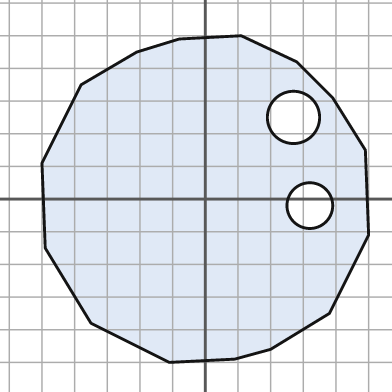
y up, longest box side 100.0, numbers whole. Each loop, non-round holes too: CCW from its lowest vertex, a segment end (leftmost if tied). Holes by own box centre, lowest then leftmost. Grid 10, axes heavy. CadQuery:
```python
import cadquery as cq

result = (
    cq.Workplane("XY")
    .moveTo(-11.0, -50.0)
    .lineTo(9.0, -49.0)
    .lineTo(20.0, -46.0)
    .lineTo(38.0, -35.0)
    .lineTo(50.0, -11.0)
    .lineTo(49.0, 15.0)
    .lineTo(39.0, 31.0)
    .lineTo(28.0, 42.0)
    .lineTo(11.0, 50.0)
    .lineTo(-8.0, 49.0)
    .lineTo(-21.0, 45.0)
    .lineTo(-38.0, 35.0)
    .lineTo(-50.0, 11.0)
    .lineTo(-49.0, -15.0)
    .lineTo(-35.0, -38.0)
    .close()
    .moveTo(32.0, -2.0)
    .circle(7.0)
    .moveTo(27.0, 25.0)
    .circle(8.0)
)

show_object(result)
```